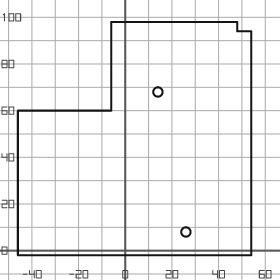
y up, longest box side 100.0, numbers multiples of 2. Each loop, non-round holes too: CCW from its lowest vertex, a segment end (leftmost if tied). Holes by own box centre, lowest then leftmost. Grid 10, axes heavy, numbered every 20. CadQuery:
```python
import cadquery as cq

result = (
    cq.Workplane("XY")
    .moveTo(-46.0, -2.0)
    .lineTo(54.0, -2.0)
    .lineTo(54.0, 94.0)
    .lineTo(48.0, 94.0)
    .lineTo(48.0, 98.0)
    .lineTo(-6.0, 98.0)
    .lineTo(-6.0, 60.0)
    .lineTo(-46.0, 60.0)
    .close()
    .moveTo(26.0, 8.0)
    .circle(2.0)
    .moveTo(14.0, 68.0)
    .circle(2.0)
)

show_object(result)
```